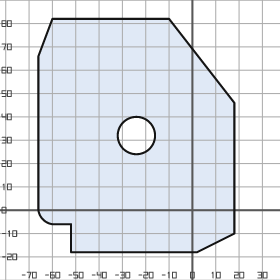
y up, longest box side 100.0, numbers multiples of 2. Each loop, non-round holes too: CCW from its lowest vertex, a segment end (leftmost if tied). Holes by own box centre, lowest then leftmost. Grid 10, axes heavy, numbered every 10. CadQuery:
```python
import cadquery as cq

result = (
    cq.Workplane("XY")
    .moveTo(-52.0, -18.0)
    .lineTo(2.0, -18.0)
    .lineTo(18.0, -10.0)
    .lineTo(18.0, 46.0)
    .lineTo(-10.0, 82.0)
    .lineTo(-60.0, 82.0)
    .lineTo(-66.0, 66.0)
    .lineTo(-66.0, 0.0)
    .threePointArc((-64.0, -4.0), (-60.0, -6.0))
    .lineTo(-52.0, -6.0)
    .close()
    .moveTo(-24.0, 32.0)
    .circle(8.0)
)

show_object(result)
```